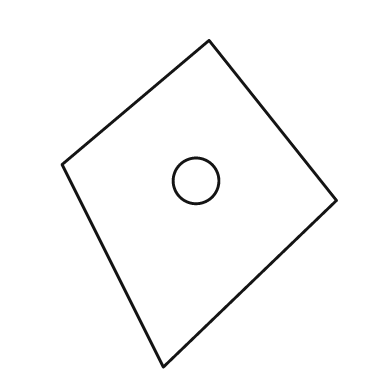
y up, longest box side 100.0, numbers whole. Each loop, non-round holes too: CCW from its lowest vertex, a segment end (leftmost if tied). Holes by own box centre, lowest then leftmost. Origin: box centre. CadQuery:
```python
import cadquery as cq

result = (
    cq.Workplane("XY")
    .moveTo(-11.0, -50.0)
    .lineTo(42.0, 1.0)
    .lineTo(3.0, 50.0)
    .lineTo(-42.0, 12.0)
    .close()
    .moveTo(-1.0, 7.0)
    .circle(7.0)
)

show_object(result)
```